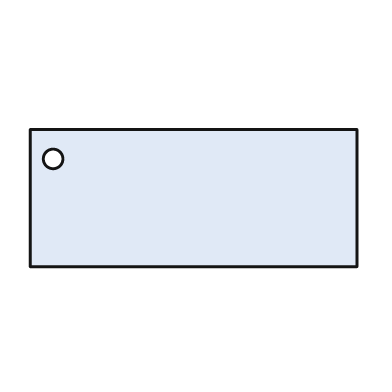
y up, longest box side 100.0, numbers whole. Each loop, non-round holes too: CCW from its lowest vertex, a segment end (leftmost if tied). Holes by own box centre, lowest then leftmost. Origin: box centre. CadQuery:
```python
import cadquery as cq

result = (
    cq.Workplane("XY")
    .moveTo(-50.0, -21.0)
    .lineTo(50.0, -21.0)
    .lineTo(50.0, 21.0)
    .lineTo(-50.0, 21.0)
    .close()
    .moveTo(-43.0, 12.0)
    .circle(3.0)
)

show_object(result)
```